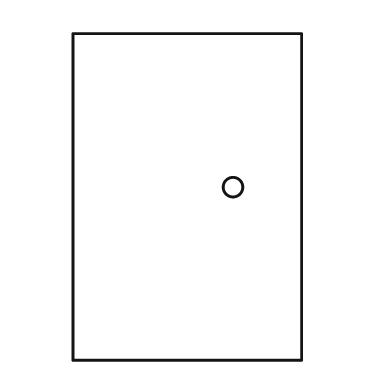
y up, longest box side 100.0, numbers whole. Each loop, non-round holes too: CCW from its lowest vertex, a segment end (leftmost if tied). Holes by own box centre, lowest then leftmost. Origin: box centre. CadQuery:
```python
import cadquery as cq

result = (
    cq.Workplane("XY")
    .moveTo(-35.0, -50.0)
    .lineTo(35.0, -50.0)
    .lineTo(35.0, 50.0)
    .lineTo(-35.0, 50.0)
    .close()
    .moveTo(14.0, 3.0)
    .circle(3.0)
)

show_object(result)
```